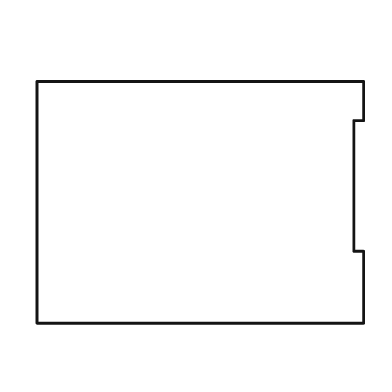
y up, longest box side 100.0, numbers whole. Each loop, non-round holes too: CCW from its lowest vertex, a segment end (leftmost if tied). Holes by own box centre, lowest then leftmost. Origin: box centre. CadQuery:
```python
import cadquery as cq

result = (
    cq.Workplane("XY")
    .moveTo(-50.0, -37.0)
    .lineTo(50.0, -37.0)
    .lineTo(50.0, -15.0)
    .lineTo(47.0, -15.0)
    .lineTo(47.0, 25.0)
    .lineTo(50.0, 25.0)
    .lineTo(50.0, 37.0)
    .lineTo(-50.0, 37.0)
    .close()
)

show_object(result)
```